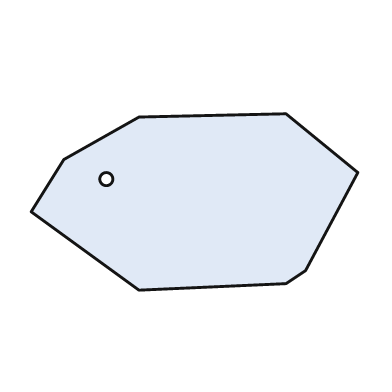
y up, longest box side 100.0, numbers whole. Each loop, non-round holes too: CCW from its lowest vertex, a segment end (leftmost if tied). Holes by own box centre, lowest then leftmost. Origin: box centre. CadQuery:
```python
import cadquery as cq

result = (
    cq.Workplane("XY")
    .moveTo(-17.0, -27.0)
    .lineTo(28.0, -25.0)
    .lineTo(34.0, -21.0)
    .lineTo(50.0, 9.0)
    .lineTo(28.0, 27.0)
    .lineTo(-17.0, 26.0)
    .lineTo(-40.0, 13.0)
    .lineTo(-50.0, -3.0)
    .close()
    .moveTo(-27.0, 7.0)
    .circle(2.0)
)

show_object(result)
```